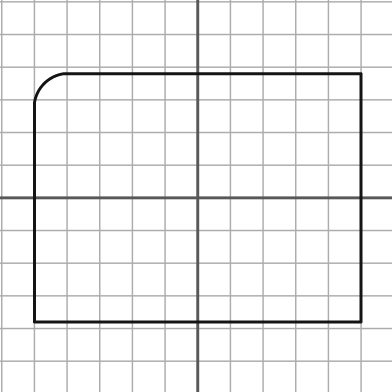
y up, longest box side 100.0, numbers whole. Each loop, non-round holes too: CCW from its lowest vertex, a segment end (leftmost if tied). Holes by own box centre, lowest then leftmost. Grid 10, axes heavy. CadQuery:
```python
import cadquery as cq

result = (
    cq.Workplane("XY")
    .moveTo(-50.0, -38.0)
    .lineTo(50.0, -38.0)
    .lineTo(50.0, 38.0)
    .lineTo(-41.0, 38.0)
    .threePointArc((-47.0, 35.0), (-50.0, 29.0))
    .close()
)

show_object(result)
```